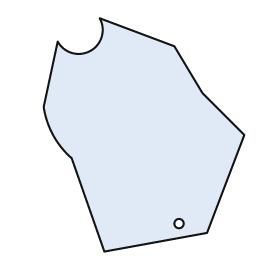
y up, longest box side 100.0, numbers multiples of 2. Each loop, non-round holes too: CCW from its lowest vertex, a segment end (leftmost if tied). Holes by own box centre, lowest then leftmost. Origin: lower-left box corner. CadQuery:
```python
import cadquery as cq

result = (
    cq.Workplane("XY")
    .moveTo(26.0, 0.0)
    .lineTo(70.0, 8.0)
    .lineTo(86.0, 50.0)
    .lineTo(68.0, 68.0)
    .lineTo(56.0, 88.0)
    .lineTo(24.0, 100.0)
    .threePointArc((20.0, 86.0), (6.0, 90.0))
    .lineTo(0.0, 62.0)
    .threePointArc((4.0, 50.0), (12.0, 40.0))
    .close()
    .moveTo(58.0, 12.0)
    .circle(2.0)
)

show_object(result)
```